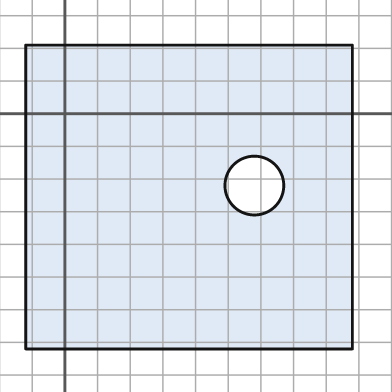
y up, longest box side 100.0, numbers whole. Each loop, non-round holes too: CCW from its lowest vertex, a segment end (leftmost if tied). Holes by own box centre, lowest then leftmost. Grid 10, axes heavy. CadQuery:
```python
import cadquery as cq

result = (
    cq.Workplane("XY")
    .moveTo(-12.0, -72.0)
    .lineTo(88.0, -72.0)
    .lineTo(88.0, 21.0)
    .lineTo(-12.0, 21.0)
    .close()
    .moveTo(58.0, -22.0)
    .circle(9.0)
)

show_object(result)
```